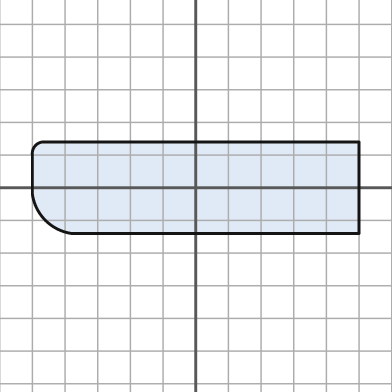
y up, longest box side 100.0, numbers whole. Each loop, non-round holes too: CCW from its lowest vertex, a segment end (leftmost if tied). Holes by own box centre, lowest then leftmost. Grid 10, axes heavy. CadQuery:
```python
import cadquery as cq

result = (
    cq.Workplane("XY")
    .moveTo(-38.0, -14.0)
    .lineTo(50.0, -14.0)
    .lineTo(50.0, 14.0)
    .lineTo(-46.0, 14.0)
    .threePointArc((-49.0, 13.0), (-50.0, 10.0))
    .lineTo(-50.0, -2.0)
    .threePointArc((-46.0, -10.0), (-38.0, -14.0))
    .close()
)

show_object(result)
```